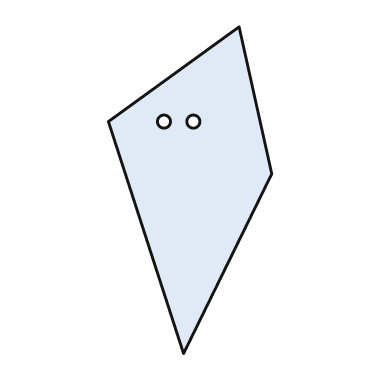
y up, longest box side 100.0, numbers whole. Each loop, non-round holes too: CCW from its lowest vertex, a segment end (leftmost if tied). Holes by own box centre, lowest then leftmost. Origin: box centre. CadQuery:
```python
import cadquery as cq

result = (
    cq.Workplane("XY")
    .moveTo(-2.0, -50.0)
    .lineTo(25.0, 5.0)
    .lineTo(15.0, 50.0)
    .lineTo(-25.0, 21.0)
    .close()
    .moveTo(-8.0, 21.0)
    .circle(2.0)
    .moveTo(1.0, 21.0)
    .circle(2.0)
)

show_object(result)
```